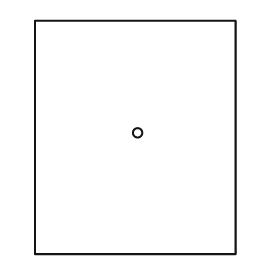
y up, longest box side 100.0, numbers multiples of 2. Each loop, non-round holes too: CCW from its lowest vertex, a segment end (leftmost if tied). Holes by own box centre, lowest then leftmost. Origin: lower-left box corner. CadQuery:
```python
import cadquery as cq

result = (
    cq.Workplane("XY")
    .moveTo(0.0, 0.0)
    .lineTo(86.0, 0.0)
    .lineTo(86.0, 100.0)
    .lineTo(0.0, 100.0)
    .close()
    .moveTo(44.0, 52.0)
    .circle(2.0)
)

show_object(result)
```